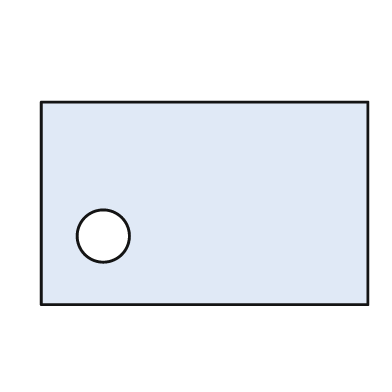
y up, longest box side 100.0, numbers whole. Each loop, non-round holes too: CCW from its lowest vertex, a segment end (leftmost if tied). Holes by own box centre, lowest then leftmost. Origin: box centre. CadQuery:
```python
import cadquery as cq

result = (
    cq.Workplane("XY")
    .moveTo(-50.0, -31.0)
    .lineTo(50.0, -31.0)
    .lineTo(50.0, 31.0)
    .lineTo(-50.0, 31.0)
    .close()
    .moveTo(-31.0, -10.0)
    .circle(8.0)
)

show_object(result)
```